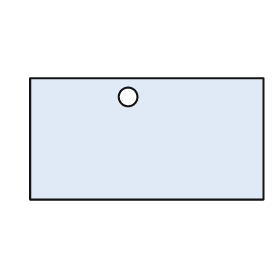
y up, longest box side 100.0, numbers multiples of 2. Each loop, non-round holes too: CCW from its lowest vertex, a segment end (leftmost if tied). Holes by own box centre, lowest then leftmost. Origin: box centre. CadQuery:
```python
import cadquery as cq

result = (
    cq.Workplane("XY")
    .moveTo(-50.0, -26.0)
    .lineTo(50.0, -26.0)
    .lineTo(50.0, 26.0)
    .lineTo(-50.0, 26.0)
    .close()
    .moveTo(-8.0, 18.0)
    .circle(4.0)
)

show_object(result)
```